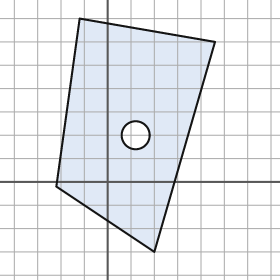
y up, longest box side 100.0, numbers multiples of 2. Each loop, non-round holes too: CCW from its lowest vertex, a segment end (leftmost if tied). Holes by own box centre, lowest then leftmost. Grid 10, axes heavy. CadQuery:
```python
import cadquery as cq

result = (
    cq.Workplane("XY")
    .moveTo(20.0, -30.0)
    .lineTo(46.0, 60.0)
    .lineTo(-12.0, 70.0)
    .lineTo(-22.0, -2.0)
    .close()
    .moveTo(12.0, 20.0)
    .circle(6.0)
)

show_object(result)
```